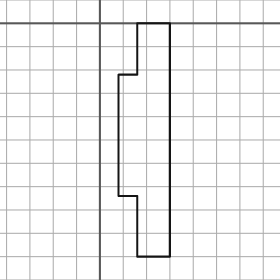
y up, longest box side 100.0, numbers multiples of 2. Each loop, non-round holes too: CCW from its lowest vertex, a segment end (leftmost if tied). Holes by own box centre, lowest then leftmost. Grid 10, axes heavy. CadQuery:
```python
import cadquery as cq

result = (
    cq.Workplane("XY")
    .moveTo(16.0, -100.0)
    .lineTo(30.0, -100.0)
    .lineTo(30.0, 0.0)
    .lineTo(16.0, 0.0)
    .lineTo(16.0, -22.0)
    .lineTo(8.0, -22.0)
    .lineTo(8.0, -74.0)
    .lineTo(16.0, -74.0)
    .close()
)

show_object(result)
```